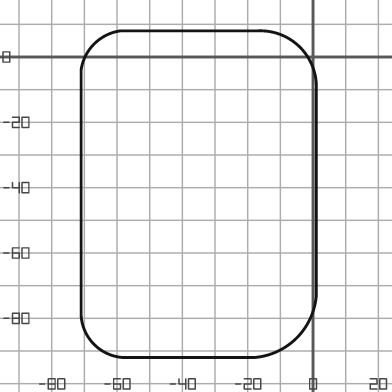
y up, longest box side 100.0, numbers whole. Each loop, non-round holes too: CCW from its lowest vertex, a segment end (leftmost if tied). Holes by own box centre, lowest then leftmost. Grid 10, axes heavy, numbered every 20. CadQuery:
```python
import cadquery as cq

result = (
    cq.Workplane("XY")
    .moveTo(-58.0, -92.0)
    .lineTo(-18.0, -92.0)
    .threePointArc((-5.0, -86.0), (1.0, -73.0))
    .lineTo(1.0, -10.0)
    .threePointArc((-4.0, 3.0), (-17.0, 8.0))
    .lineTo(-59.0, 8.0)
    .threePointArc((-67.0, 4.0), (-71.0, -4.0))
    .lineTo(-71.0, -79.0)
    .threePointArc((-67.0, -88.0), (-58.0, -92.0))
    .close()
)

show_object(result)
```